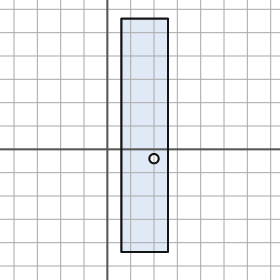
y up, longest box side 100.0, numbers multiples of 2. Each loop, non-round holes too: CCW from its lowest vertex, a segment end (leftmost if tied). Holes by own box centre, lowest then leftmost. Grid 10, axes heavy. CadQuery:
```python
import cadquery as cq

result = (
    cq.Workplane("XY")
    .moveTo(6.0, -44.0)
    .lineTo(26.0, -44.0)
    .lineTo(26.0, 56.0)
    .lineTo(6.0, 56.0)
    .close()
    .moveTo(20.0, -4.0)
    .circle(2.0)
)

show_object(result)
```